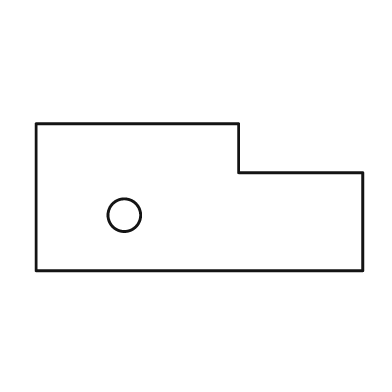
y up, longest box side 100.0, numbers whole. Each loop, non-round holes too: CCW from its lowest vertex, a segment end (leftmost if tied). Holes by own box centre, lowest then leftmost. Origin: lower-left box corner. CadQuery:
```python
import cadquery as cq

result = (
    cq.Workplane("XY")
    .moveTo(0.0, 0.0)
    .lineTo(100.0, 0.0)
    .lineTo(100.0, 30.0)
    .lineTo(62.0, 30.0)
    .lineTo(62.0, 45.0)
    .lineTo(0.0, 45.0)
    .close()
    .moveTo(27.0, 17.0)
    .circle(5.0)
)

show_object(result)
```